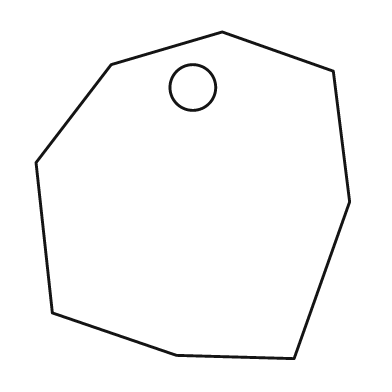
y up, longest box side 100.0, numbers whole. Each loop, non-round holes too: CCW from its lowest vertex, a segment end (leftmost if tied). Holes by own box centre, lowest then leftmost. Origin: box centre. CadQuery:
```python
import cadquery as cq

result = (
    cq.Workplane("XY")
    .moveTo(31.0, -50.0)
    .lineTo(48.0, -2.0)
    .lineTo(43.0, 38.0)
    .lineTo(9.0, 50.0)
    .lineTo(-25.0, 40.0)
    .lineTo(-48.0, 10.0)
    .lineTo(-43.0, -36.0)
    .lineTo(-5.0, -49.0)
    .close()
    .moveTo(0.0, 33.0)
    .circle(7.0)
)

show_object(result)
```